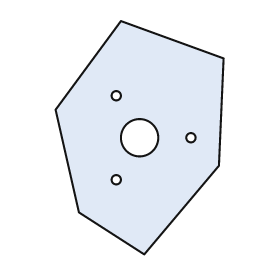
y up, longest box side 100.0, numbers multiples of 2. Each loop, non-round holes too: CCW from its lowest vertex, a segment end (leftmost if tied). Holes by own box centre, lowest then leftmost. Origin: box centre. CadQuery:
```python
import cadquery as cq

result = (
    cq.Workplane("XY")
    .moveTo(2.0, -50.0)
    .lineTo(34.0, -12.0)
    .lineTo(36.0, 34.0)
    .lineTo(-8.0, 50.0)
    .lineTo(-36.0, 12.0)
    .lineTo(-26.0, -32.0)
    .close()
    .moveTo(-10.0, -18.0)
    .circle(2.0)
    .moveTo(0.0, 0.0)
    .circle(8.0)
    .moveTo(22.0, 0.0)
    .circle(2.0)
    .moveTo(-10.0, 18.0)
    .circle(2.0)
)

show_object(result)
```